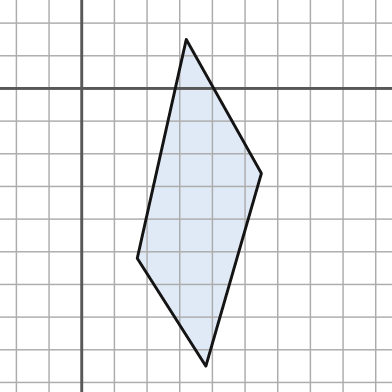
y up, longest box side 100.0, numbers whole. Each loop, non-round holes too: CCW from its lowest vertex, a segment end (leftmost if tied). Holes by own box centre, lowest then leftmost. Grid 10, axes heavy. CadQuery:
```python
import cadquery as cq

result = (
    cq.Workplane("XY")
    .moveTo(38.0, -85.0)
    .lineTo(55.0, -26.0)
    .lineTo(32.0, 15.0)
    .lineTo(17.0, -52.0)
    .close()
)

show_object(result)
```